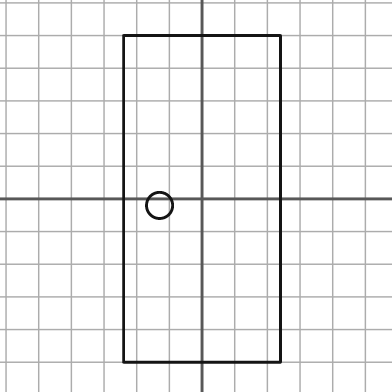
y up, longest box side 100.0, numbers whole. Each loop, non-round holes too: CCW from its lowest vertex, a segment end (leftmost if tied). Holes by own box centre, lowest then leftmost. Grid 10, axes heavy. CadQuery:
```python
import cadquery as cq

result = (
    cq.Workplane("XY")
    .moveTo(-24.0, -50.0)
    .lineTo(24.0, -50.0)
    .lineTo(24.0, 50.0)
    .lineTo(-24.0, 50.0)
    .close()
    .moveTo(-13.0, -2.0)
    .circle(4.0)
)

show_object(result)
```